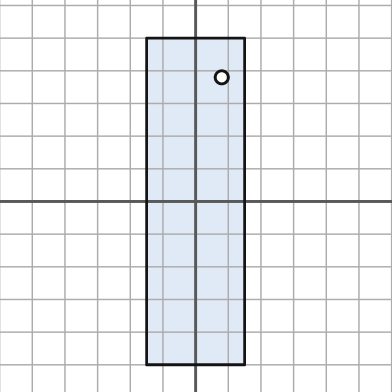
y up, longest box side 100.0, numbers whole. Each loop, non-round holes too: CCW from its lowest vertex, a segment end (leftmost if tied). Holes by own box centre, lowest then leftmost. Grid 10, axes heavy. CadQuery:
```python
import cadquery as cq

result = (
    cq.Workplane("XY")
    .moveTo(-15.0, -50.0)
    .lineTo(15.0, -50.0)
    .lineTo(15.0, 50.0)
    .lineTo(-15.0, 50.0)
    .close()
    .moveTo(8.0, 38.0)
    .circle(2.0)
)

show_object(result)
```